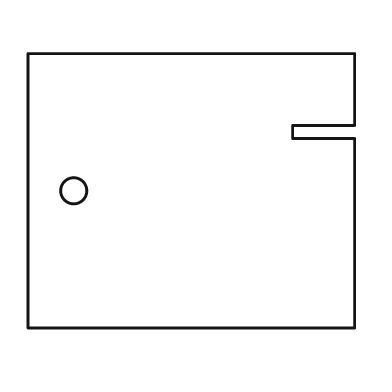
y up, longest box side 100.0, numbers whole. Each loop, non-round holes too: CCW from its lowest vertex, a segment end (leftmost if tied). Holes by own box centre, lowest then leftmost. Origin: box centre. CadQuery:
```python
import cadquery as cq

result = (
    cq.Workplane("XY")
    .moveTo(-50.0, -42.0)
    .lineTo(50.0, -42.0)
    .lineTo(50.0, 16.0)
    .lineTo(31.0, 16.0)
    .lineTo(31.0, 20.0)
    .lineTo(50.0, 20.0)
    .lineTo(50.0, 42.0)
    .lineTo(-50.0, 42.0)
    .close()
    .moveTo(-36.0, 0.0)
    .circle(4.0)
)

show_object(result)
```